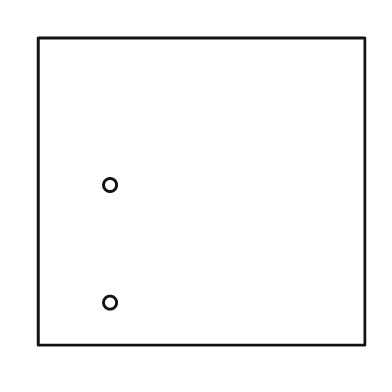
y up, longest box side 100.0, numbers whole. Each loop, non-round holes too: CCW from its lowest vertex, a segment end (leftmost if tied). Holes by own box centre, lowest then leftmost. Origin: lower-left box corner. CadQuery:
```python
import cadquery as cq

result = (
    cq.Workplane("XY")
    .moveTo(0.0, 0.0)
    .lineTo(100.0, 0.0)
    .lineTo(100.0, 94.0)
    .lineTo(0.0, 94.0)
    .close()
    .moveTo(22.0, 13.0)
    .circle(2.0)
    .moveTo(22.0, 49.0)
    .circle(2.0)
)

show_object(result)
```